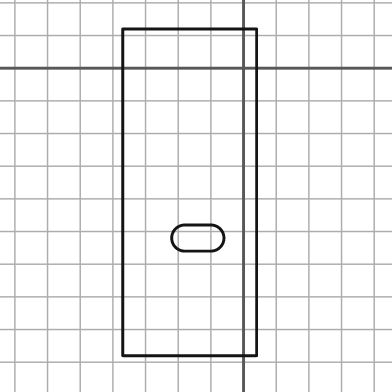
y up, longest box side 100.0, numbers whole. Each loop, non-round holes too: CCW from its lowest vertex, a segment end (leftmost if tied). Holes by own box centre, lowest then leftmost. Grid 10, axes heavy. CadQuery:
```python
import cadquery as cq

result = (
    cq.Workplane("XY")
    .moveTo(-37.0, -88.0)
    .lineTo(4.0, -88.0)
    .lineTo(4.0, 12.0)
    .lineTo(-37.0, 12.0)
    .close()
    .moveTo(-18.0, -56.0)
    .lineTo(-10.0, -56.0)
    .threePointArc((-6.0, -52.0), (-10.0, -48.0))
    .lineTo(-18.0, -48.0)
    .threePointArc((-22.0, -52.0), (-18.0, -56.0))
    .close()
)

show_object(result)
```